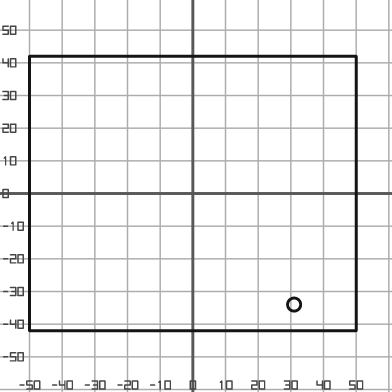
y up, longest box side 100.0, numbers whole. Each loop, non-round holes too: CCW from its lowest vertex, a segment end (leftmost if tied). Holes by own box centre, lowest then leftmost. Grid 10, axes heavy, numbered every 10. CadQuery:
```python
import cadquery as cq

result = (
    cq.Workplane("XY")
    .moveTo(-50.0, -42.0)
    .lineTo(50.0, -42.0)
    .lineTo(50.0, 42.0)
    .lineTo(-50.0, 42.0)
    .close()
    .moveTo(31.0, -34.0)
    .circle(2.0)
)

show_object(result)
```